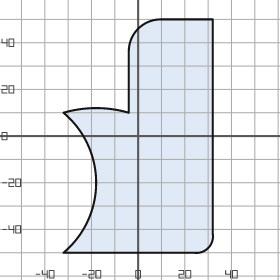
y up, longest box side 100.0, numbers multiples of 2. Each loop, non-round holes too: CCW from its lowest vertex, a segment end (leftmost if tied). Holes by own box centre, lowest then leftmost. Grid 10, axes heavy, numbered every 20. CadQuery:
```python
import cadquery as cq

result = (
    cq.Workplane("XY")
    .moveTo(-32.0, -50.0)
    .lineTo(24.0, -50.0)
    .threePointArc((30.0, -48.0), (32.0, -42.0))
    .lineTo(32.0, 50.0)
    .lineTo(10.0, 50.0)
    .threePointArc((0.0, 46.0), (-4.0, 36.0))
    .lineTo(-4.0, 10.0)
    .threePointArc((-18.0, 12.0), (-32.0, 10.0))
    .threePointArc((-18.0, -20.0), (-32.0, -50.0))
    .close()
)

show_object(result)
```